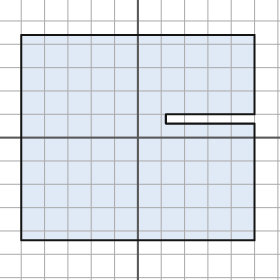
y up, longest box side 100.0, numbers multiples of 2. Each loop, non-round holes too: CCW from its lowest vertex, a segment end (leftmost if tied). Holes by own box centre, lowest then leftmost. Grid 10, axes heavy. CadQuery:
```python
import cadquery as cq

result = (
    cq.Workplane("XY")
    .moveTo(-50.0, -44.0)
    .lineTo(50.0, -44.0)
    .lineTo(50.0, 6.0)
    .lineTo(12.0, 6.0)
    .lineTo(12.0, 10.0)
    .lineTo(50.0, 10.0)
    .lineTo(50.0, 44.0)
    .lineTo(-50.0, 44.0)
    .close()
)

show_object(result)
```